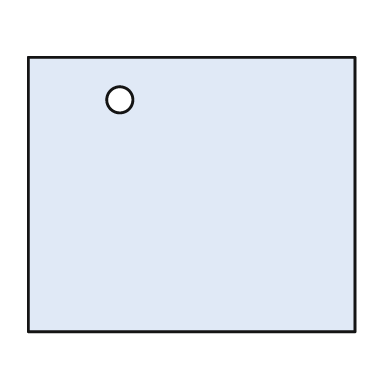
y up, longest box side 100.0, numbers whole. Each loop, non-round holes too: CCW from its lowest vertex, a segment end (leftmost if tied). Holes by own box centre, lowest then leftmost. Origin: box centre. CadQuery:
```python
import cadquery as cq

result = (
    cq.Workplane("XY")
    .moveTo(-50.0, -42.0)
    .lineTo(50.0, -42.0)
    .lineTo(50.0, 42.0)
    .lineTo(-50.0, 42.0)
    .close()
    .moveTo(-22.0, 29.0)
    .circle(4.0)
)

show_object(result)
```